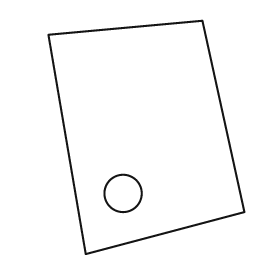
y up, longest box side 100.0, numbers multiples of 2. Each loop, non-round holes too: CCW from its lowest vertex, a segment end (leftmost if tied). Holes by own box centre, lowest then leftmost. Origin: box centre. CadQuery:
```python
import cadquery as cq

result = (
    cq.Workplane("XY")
    .moveTo(-26.0, -50.0)
    .lineTo(42.0, -32.0)
    .lineTo(24.0, 50.0)
    .lineTo(-42.0, 44.0)
    .close()
    .moveTo(-10.0, -24.0)
    .circle(8.0)
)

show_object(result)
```